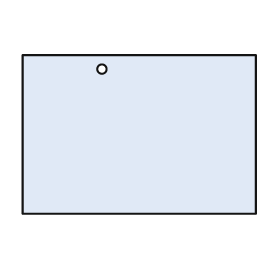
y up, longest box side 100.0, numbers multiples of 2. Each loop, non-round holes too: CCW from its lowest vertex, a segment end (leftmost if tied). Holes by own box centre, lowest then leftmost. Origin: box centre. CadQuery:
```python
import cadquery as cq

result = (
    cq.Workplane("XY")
    .moveTo(-50.0, -34.0)
    .lineTo(50.0, -34.0)
    .lineTo(50.0, 34.0)
    .lineTo(-50.0, 34.0)
    .close()
    .moveTo(-16.0, 28.0)
    .circle(2.0)
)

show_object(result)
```